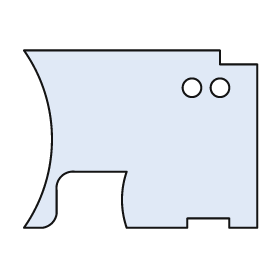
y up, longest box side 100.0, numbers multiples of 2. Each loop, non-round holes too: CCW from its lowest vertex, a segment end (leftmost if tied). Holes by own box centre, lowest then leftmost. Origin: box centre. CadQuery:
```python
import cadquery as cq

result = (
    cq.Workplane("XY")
    .moveTo(-50.0, -38.0)
    .lineTo(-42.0, -38.0)
    .threePointArc((-38.0, -36.0), (-36.0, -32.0))
    .lineTo(-36.0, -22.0)
    .threePointArc((-34.0, -16.0), (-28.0, -14.0))
    .lineTo(-6.0, -14.0)
    .threePointArc((-8.0, -26.0), (-6.0, -38.0))
    .lineTo(20.0, -38.0)
    .lineTo(20.0, -34.0)
    .lineTo(38.0, -34.0)
    .lineTo(38.0, -38.0)
    .lineTo(50.0, -38.0)
    .lineTo(50.0, 32.0)
    .lineTo(34.0, 32.0)
    .lineTo(34.0, 38.0)
    .lineTo(-50.0, 38.0)
    .threePointArc((-38.0, 0.0), (-50.0, -38.0))
    .close()
    .moveTo(22.0, 22.0)
    .circle(4.0)
    .moveTo(34.0, 22.0)
    .circle(4.0)
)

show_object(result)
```